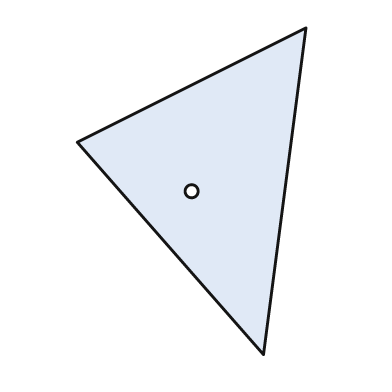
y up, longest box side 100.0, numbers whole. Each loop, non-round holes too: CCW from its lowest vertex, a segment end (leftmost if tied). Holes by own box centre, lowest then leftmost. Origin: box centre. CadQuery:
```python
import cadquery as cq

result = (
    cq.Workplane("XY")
    .moveTo(22.0, -50.0)
    .lineTo(35.0, 50.0)
    .lineTo(-35.0, 15.0)
    .close()
    .moveTo(0.0, 0.0)
    .circle(2.0)
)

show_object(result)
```